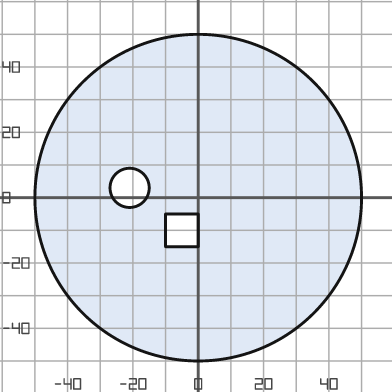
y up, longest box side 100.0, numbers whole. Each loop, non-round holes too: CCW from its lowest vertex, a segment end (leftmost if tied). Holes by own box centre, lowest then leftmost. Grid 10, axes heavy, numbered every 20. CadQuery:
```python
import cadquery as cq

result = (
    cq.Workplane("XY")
    .moveTo(0.0, 0.0)
    .circle(50.0)
    .moveTo(-10.0, -15.0)
    .lineTo(0.0, -15.0)
    .lineTo(0.0, -5.0)
    .lineTo(-10.0, -5.0)
    .close()
    .moveTo(-21.0, 3.0)
    .circle(6.0)
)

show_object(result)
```